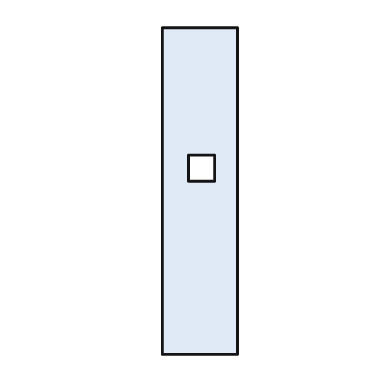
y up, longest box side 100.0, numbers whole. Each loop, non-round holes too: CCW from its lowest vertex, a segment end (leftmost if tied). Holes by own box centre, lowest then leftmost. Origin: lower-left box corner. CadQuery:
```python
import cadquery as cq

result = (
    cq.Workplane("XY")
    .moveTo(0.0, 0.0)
    .lineTo(23.0, 0.0)
    .lineTo(23.0, 100.0)
    .lineTo(0.0, 100.0)
    .close()
    .moveTo(8.0, 53.0)
    .lineTo(16.0, 53.0)
    .lineTo(16.0, 61.0)
    .lineTo(8.0, 61.0)
    .close()
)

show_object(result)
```